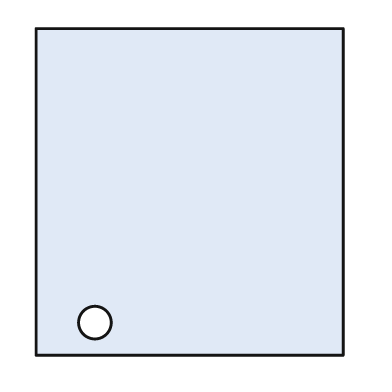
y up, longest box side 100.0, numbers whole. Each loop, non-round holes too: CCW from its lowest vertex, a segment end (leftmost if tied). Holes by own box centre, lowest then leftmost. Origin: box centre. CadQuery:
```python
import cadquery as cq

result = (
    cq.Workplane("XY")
    .moveTo(-47.0, -50.0)
    .lineTo(47.0, -50.0)
    .lineTo(47.0, 50.0)
    .lineTo(-47.0, 50.0)
    .close()
    .moveTo(-29.0, -40.0)
    .circle(5.0)
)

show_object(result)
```